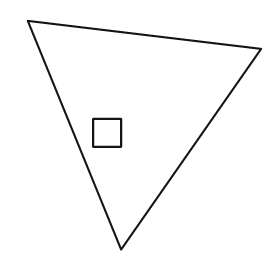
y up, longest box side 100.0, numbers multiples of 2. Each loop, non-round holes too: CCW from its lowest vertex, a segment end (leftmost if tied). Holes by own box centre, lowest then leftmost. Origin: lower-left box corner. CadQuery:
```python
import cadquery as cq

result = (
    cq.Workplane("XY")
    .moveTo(40.0, 0.0)
    .lineTo(100.0, 86.0)
    .lineTo(0.0, 98.0)
    .close()
    .moveTo(28.0, 44.0)
    .lineTo(40.0, 44.0)
    .lineTo(40.0, 56.0)
    .lineTo(28.0, 56.0)
    .close()
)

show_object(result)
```